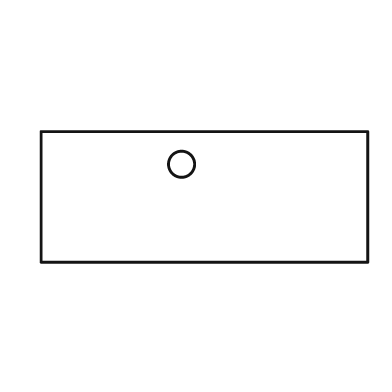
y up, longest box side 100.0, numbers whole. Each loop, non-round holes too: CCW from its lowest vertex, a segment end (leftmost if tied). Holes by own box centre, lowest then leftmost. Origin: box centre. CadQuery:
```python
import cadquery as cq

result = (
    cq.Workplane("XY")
    .moveTo(-50.0, -20.0)
    .lineTo(50.0, -20.0)
    .lineTo(50.0, 20.0)
    .lineTo(-50.0, 20.0)
    .close()
    .moveTo(-7.0, 10.0)
    .circle(4.0)
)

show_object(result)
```